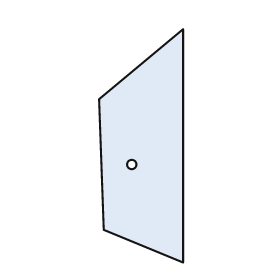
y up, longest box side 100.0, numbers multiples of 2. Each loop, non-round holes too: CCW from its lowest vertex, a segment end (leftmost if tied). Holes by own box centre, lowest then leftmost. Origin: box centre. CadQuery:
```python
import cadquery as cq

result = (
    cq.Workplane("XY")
    .moveTo(18.0, -50.0)
    .lineTo(18.0, 50.0)
    .lineTo(-18.0, 20.0)
    .lineTo(-16.0, -36.0)
    .close()
    .moveTo(-4.0, -8.0)
    .circle(2.0)
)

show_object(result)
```